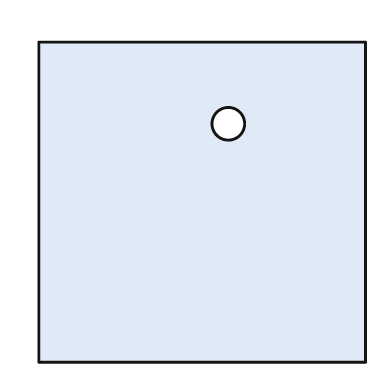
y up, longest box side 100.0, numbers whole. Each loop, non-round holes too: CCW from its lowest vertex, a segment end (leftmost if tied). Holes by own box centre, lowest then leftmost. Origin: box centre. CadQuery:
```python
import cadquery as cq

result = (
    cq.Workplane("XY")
    .moveTo(-50.0, -49.0)
    .lineTo(50.0, -49.0)
    .lineTo(50.0, 49.0)
    .lineTo(-50.0, 49.0)
    .close()
    .moveTo(8.0, 24.0)
    .circle(5.0)
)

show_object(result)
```